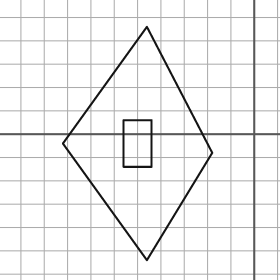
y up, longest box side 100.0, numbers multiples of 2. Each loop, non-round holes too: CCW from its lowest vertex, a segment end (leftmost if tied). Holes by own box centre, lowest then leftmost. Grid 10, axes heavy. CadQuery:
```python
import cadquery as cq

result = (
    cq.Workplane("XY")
    .moveTo(-46.0, -54.0)
    .lineTo(-18.0, -8.0)
    .lineTo(-46.0, 46.0)
    .lineTo(-82.0, -4.0)
    .close()
    .moveTo(-56.0, -14.0)
    .lineTo(-44.0, -14.0)
    .lineTo(-44.0, 6.0)
    .lineTo(-56.0, 6.0)
    .close()
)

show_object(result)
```